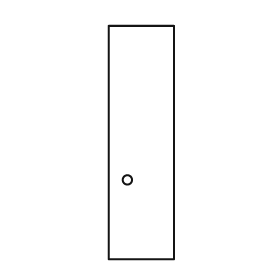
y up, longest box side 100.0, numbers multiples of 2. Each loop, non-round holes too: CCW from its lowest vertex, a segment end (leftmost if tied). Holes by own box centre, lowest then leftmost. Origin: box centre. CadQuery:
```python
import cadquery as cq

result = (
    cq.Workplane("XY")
    .moveTo(-14.0, -50.0)
    .lineTo(14.0, -50.0)
    .lineTo(14.0, 50.0)
    .lineTo(-14.0, 50.0)
    .close()
    .moveTo(-6.0, -16.0)
    .circle(2.0)
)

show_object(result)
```